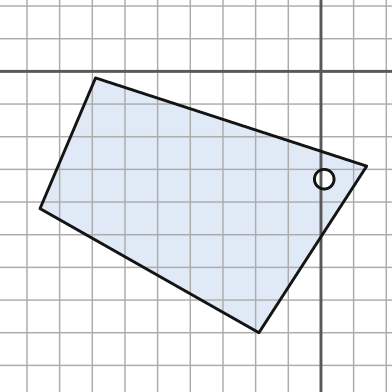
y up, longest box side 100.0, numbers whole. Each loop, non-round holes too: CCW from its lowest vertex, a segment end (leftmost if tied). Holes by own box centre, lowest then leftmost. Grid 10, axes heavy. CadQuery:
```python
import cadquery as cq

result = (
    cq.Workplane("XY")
    .moveTo(-19.0, -80.0)
    .lineTo(14.0, -29.0)
    .lineTo(-69.0, -2.0)
    .lineTo(-86.0, -42.0)
    .close()
    .moveTo(1.0, -33.0)
    .circle(3.0)
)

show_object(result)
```